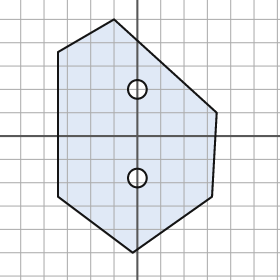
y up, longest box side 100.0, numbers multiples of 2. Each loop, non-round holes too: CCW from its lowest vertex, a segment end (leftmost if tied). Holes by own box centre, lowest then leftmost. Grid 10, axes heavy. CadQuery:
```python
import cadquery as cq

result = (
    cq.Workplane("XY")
    .moveTo(-2.0, -50.0)
    .lineTo(32.0, -26.0)
    .lineTo(34.0, 10.0)
    .lineTo(-10.0, 50.0)
    .lineTo(-34.0, 36.0)
    .lineTo(-34.0, -26.0)
    .close()
    .moveTo(0.0, -18.0)
    .circle(4.0)
    .moveTo(0.0, 20.0)
    .circle(4.0)
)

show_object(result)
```